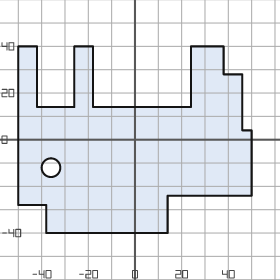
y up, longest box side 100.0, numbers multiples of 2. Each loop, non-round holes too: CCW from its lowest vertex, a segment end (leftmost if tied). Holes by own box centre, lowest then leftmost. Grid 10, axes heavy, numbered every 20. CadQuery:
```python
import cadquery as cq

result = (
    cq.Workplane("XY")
    .moveTo(-38.0, -40.0)
    .lineTo(14.0, -40.0)
    .lineTo(14.0, -24.0)
    .lineTo(50.0, -24.0)
    .lineTo(50.0, 4.0)
    .lineTo(46.0, 4.0)
    .lineTo(46.0, 28.0)
    .lineTo(38.0, 28.0)
    .lineTo(38.0, 40.0)
    .lineTo(24.0, 40.0)
    .lineTo(24.0, 14.0)
    .lineTo(-18.0, 14.0)
    .lineTo(-18.0, 40.0)
    .lineTo(-26.0, 40.0)
    .lineTo(-26.0, 14.0)
    .lineTo(-42.0, 14.0)
    .lineTo(-42.0, 40.0)
    .lineTo(-50.0, 40.0)
    .lineTo(-50.0, -28.0)
    .lineTo(-38.0, -28.0)
    .close()
    .moveTo(-36.0, -12.0)
    .circle(4.0)
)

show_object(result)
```